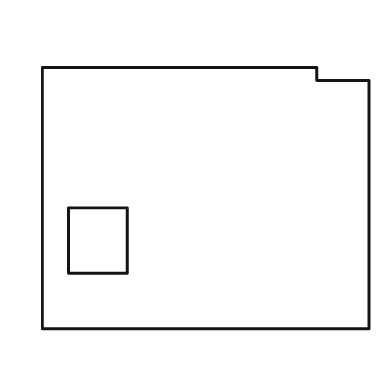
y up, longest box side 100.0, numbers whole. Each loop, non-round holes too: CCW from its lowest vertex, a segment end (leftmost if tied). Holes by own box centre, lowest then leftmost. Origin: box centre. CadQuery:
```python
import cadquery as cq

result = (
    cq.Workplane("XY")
    .moveTo(-50.0, -40.0)
    .lineTo(50.0, -40.0)
    .lineTo(50.0, 36.0)
    .lineTo(34.0, 36.0)
    .lineTo(34.0, 40.0)
    .lineTo(-50.0, 40.0)
    .close()
    .moveTo(-42.0, -23.0)
    .lineTo(-24.0, -23.0)
    .lineTo(-24.0, -3.0)
    .lineTo(-42.0, -3.0)
    .close()
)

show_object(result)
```